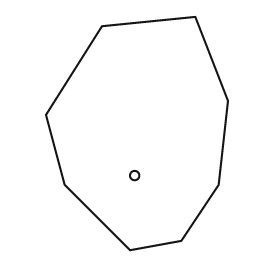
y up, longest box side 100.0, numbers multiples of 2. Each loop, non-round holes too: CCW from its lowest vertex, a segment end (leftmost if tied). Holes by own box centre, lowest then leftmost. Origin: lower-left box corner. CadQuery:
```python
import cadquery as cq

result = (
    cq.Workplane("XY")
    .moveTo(36.0, 0.0)
    .lineTo(58.0, 4.0)
    .lineTo(74.0, 28.0)
    .lineTo(78.0, 64.0)
    .lineTo(64.0, 100.0)
    .lineTo(24.0, 96.0)
    .lineTo(0.0, 58.0)
    .lineTo(8.0, 28.0)
    .close()
    .moveTo(38.0, 32.0)
    .circle(2.0)
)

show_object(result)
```